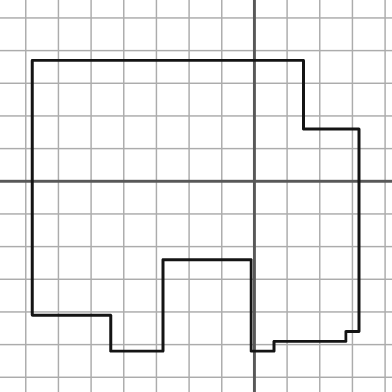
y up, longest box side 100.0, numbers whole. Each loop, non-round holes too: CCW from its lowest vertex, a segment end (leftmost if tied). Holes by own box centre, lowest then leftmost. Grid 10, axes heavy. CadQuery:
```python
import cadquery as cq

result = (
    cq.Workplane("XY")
    .moveTo(-44.0, -52.0)
    .lineTo(-28.0, -52.0)
    .lineTo(-28.0, -24.0)
    .lineTo(-1.0, -24.0)
    .lineTo(-1.0, -52.0)
    .lineTo(6.0, -52.0)
    .lineTo(6.0, -49.0)
    .lineTo(28.0, -49.0)
    .lineTo(28.0, -46.0)
    .lineTo(32.0, -46.0)
    .lineTo(32.0, 16.0)
    .lineTo(15.0, 16.0)
    .lineTo(15.0, 37.0)
    .lineTo(-68.0, 37.0)
    .lineTo(-68.0, -41.0)
    .lineTo(-44.0, -41.0)
    .close()
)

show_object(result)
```